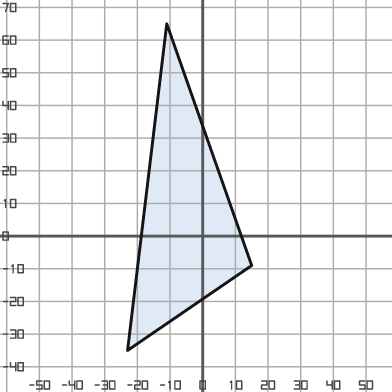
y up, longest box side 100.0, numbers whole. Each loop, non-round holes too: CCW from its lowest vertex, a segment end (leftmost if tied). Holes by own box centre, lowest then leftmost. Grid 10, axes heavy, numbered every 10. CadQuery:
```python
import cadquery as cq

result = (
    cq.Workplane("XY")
    .moveTo(-23.0, -35.0)
    .lineTo(15.0, -9.0)
    .lineTo(-11.0, 65.0)
    .close()
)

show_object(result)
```